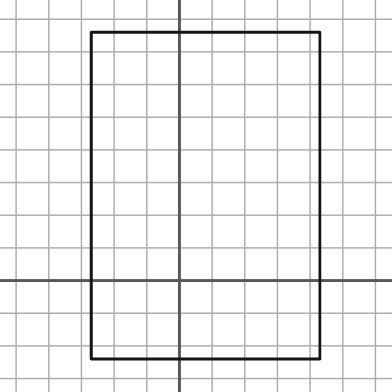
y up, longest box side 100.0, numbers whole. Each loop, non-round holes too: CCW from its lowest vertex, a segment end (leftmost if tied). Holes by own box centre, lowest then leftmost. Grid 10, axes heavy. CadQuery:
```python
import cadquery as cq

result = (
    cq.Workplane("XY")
    .moveTo(-27.0, -24.0)
    .lineTo(43.0, -24.0)
    .lineTo(43.0, 76.0)
    .lineTo(-27.0, 76.0)
    .close()
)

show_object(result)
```